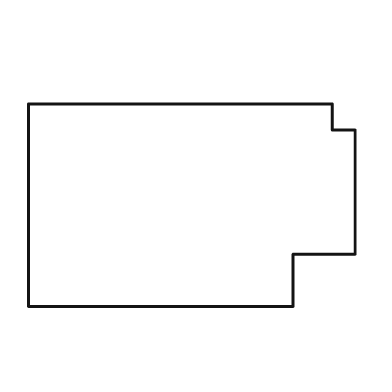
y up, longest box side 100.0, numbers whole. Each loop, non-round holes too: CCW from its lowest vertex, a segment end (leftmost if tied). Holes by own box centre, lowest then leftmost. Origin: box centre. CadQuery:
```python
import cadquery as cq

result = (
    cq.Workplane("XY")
    .moveTo(-50.0, -31.0)
    .lineTo(31.0, -31.0)
    .lineTo(31.0, -15.0)
    .lineTo(50.0, -15.0)
    .lineTo(50.0, 23.0)
    .lineTo(43.0, 23.0)
    .lineTo(43.0, 31.0)
    .lineTo(-50.0, 31.0)
    .close()
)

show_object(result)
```